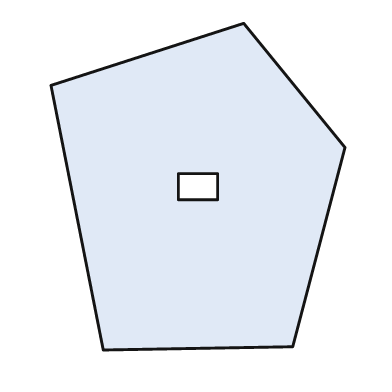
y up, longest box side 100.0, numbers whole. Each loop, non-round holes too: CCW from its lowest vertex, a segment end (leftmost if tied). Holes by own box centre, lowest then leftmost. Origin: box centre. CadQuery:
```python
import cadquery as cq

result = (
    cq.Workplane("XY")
    .moveTo(-29.0, -50.0)
    .lineTo(29.0, -49.0)
    .lineTo(45.0, 12.0)
    .lineTo(14.0, 50.0)
    .lineTo(-45.0, 31.0)
    .close()
    .moveTo(-6.0, -4.0)
    .lineTo(6.0, -4.0)
    .lineTo(6.0, 4.0)
    .lineTo(-6.0, 4.0)
    .close()
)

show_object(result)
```